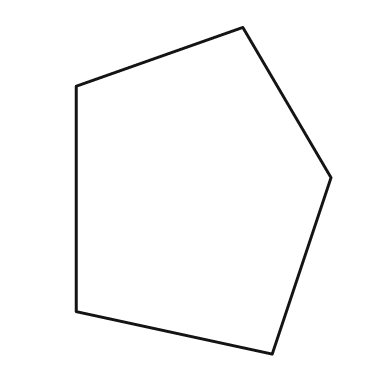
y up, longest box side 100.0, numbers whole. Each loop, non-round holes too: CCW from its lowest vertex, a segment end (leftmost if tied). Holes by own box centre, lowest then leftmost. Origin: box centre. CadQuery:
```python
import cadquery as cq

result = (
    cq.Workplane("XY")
    .moveTo(21.0, -50.0)
    .lineTo(39.0, 4.0)
    .lineTo(12.0, 50.0)
    .lineTo(-39.0, 32.0)
    .lineTo(-39.0, -37.0)
    .close()
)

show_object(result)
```